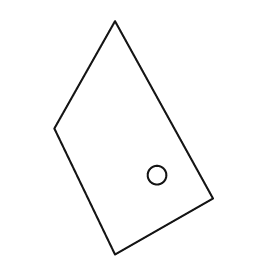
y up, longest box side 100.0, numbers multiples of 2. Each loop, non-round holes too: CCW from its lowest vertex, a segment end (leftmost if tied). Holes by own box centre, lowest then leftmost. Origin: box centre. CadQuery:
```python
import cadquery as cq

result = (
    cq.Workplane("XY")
    .moveTo(-8.0, -50.0)
    .lineTo(34.0, -26.0)
    .lineTo(-8.0, 50.0)
    .lineTo(-34.0, 4.0)
    .close()
    .moveTo(10.0, -16.0)
    .circle(4.0)
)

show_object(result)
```